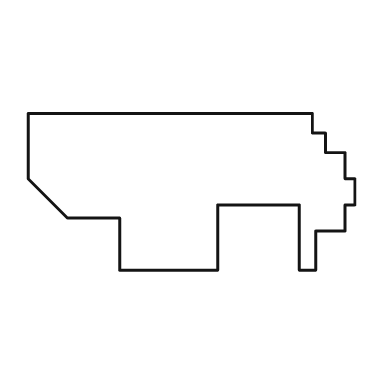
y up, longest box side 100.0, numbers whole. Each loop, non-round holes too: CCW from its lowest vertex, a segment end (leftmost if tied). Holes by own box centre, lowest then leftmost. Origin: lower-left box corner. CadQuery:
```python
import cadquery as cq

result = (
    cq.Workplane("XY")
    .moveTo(28.0, 0.0)
    .lineTo(58.0, 0.0)
    .lineTo(58.0, 20.0)
    .lineTo(83.0, 20.0)
    .lineTo(83.0, 0.0)
    .lineTo(88.0, 0.0)
    .lineTo(88.0, 12.0)
    .lineTo(97.0, 12.0)
    .lineTo(97.0, 20.0)
    .lineTo(100.0, 20.0)
    .lineTo(100.0, 28.0)
    .lineTo(97.0, 28.0)
    .lineTo(97.0, 36.0)
    .lineTo(91.0, 36.0)
    .lineTo(91.0, 42.0)
    .lineTo(87.0, 42.0)
    .lineTo(87.0, 48.0)
    .lineTo(0.0, 48.0)
    .lineTo(0.0, 28.0)
    .lineTo(12.0, 16.0)
    .lineTo(28.0, 16.0)
    .close()
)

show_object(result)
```